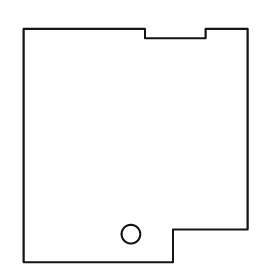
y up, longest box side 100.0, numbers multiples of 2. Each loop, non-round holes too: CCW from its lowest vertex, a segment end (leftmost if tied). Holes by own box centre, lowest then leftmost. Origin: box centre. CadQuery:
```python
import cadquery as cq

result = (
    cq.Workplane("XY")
    .moveTo(-48.0, -50.0)
    .lineTo(16.0, -50.0)
    .lineTo(16.0, -36.0)
    .lineTo(48.0, -36.0)
    .lineTo(48.0, 50.0)
    .lineTo(30.0, 50.0)
    .lineTo(30.0, 46.0)
    .lineTo(4.0, 46.0)
    .lineTo(4.0, 50.0)
    .lineTo(-48.0, 50.0)
    .close()
    .moveTo(-2.0, -38.0)
    .circle(4.0)
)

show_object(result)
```